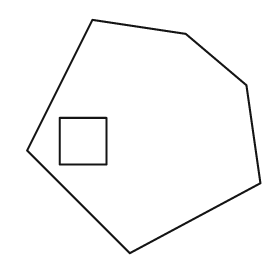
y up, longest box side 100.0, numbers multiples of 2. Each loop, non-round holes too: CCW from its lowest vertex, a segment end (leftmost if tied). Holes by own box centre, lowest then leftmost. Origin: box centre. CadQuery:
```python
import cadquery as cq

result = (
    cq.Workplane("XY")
    .moveTo(-6.0, -50.0)
    .lineTo(50.0, -20.0)
    .lineTo(44.0, 22.0)
    .lineTo(18.0, 44.0)
    .lineTo(-22.0, 50.0)
    .lineTo(-50.0, -6.0)
    .close()
    .moveTo(-36.0, -12.0)
    .lineTo(-16.0, -12.0)
    .lineTo(-16.0, 8.0)
    .lineTo(-36.0, 8.0)
    .close()
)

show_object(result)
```